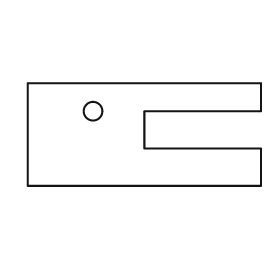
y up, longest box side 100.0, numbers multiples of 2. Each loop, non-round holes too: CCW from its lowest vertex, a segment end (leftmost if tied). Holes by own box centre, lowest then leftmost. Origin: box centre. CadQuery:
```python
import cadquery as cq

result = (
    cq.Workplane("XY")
    .moveTo(-50.0, -22.0)
    .lineTo(50.0, -22.0)
    .lineTo(50.0, -6.0)
    .lineTo(0.0, -6.0)
    .lineTo(0.0, 10.0)
    .lineTo(50.0, 10.0)
    .lineTo(50.0, 22.0)
    .lineTo(-50.0, 22.0)
    .close()
    .moveTo(-22.0, 10.0)
    .circle(4.0)
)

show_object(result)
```